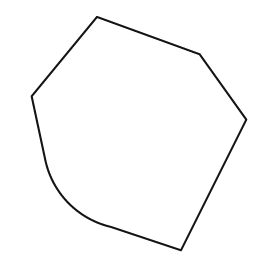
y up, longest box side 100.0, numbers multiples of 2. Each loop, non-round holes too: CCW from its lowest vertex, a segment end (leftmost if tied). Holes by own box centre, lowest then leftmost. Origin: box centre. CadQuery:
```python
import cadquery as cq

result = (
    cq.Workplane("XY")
    .moveTo(18.0, -50.0)
    .lineTo(46.0, 6.0)
    .lineTo(26.0, 34.0)
    .lineTo(-18.0, 50.0)
    .lineTo(-46.0, 16.0)
    .lineTo(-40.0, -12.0)
    .threePointArc((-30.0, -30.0), (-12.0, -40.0))
    .close()
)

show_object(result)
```